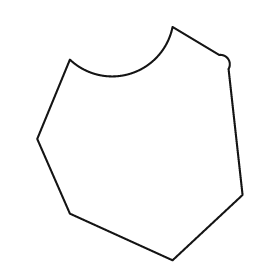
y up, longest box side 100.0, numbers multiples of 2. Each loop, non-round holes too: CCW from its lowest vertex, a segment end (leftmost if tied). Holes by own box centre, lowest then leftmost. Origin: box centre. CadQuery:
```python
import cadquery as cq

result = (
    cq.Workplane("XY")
    .moveTo(14.0, -50.0)
    .lineTo(44.0, -22.0)
    .lineTo(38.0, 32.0)
    .threePointArc((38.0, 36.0), (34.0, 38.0))
    .lineTo(14.0, 50.0)
    .threePointArc((-4.0, 30.0), (-30.0, 36.0))
    .lineTo(-44.0, 2.0)
    .lineTo(-30.0, -30.0)
    .close()
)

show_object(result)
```